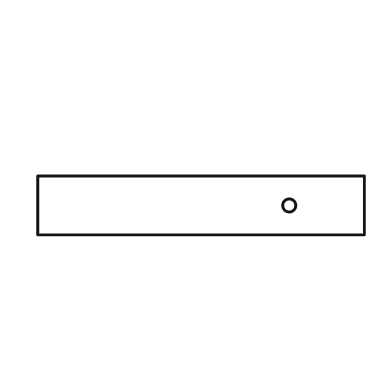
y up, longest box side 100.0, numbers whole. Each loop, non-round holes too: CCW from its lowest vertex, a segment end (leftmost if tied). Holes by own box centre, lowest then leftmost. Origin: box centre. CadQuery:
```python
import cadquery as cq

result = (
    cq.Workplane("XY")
    .moveTo(-50.0, -9.0)
    .lineTo(50.0, -9.0)
    .lineTo(50.0, 9.0)
    .lineTo(-50.0, 9.0)
    .close()
    .moveTo(27.0, 0.0)
    .circle(2.0)
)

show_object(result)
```